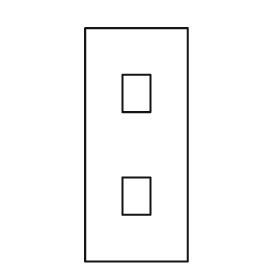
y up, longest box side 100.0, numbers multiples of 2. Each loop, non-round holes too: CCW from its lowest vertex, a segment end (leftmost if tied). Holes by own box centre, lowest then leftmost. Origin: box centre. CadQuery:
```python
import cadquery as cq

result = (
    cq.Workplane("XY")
    .moveTo(-22.0, -50.0)
    .lineTo(22.0, -50.0)
    .lineTo(22.0, 50.0)
    .lineTo(-22.0, 50.0)
    .close()
    .moveTo(-6.0, -30.0)
    .lineTo(6.0, -30.0)
    .lineTo(6.0, -14.0)
    .lineTo(-6.0, -14.0)
    .close()
    .moveTo(-6.0, 14.0)
    .lineTo(6.0, 14.0)
    .lineTo(6.0, 30.0)
    .lineTo(-6.0, 30.0)
    .close()
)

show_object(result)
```